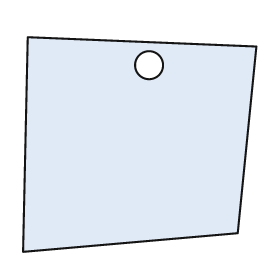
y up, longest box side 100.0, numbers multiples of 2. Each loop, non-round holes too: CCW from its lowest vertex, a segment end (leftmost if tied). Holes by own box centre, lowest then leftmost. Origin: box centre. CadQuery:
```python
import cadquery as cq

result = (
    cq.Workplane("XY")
    .moveTo(-50.0, -46.0)
    .lineTo(42.0, -38.0)
    .lineTo(50.0, 42.0)
    .lineTo(-48.0, 46.0)
    .close()
    .moveTo(4.0, 34.0)
    .circle(6.0)
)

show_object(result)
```